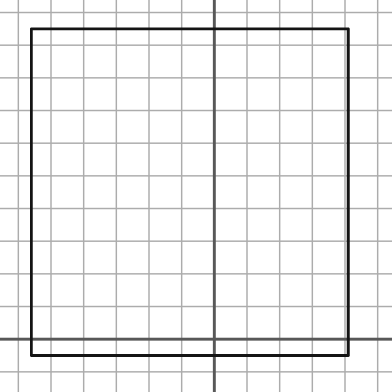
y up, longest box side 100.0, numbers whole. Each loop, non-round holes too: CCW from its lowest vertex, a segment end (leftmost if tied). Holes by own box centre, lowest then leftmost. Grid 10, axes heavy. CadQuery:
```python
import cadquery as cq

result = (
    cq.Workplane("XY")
    .moveTo(-56.0, -5.0)
    .lineTo(41.0, -5.0)
    .lineTo(41.0, 95.0)
    .lineTo(-56.0, 95.0)
    .close()
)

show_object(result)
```